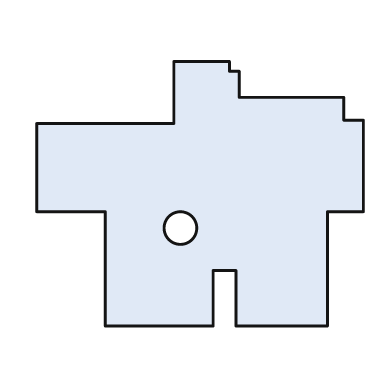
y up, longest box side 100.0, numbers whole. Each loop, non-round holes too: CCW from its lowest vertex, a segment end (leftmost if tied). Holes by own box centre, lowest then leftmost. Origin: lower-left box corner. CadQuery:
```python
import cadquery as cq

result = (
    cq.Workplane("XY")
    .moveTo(21.0, 0.0)
    .lineTo(54.0, 0.0)
    .lineTo(54.0, 17.0)
    .lineTo(61.0, 17.0)
    .lineTo(61.0, 0.0)
    .lineTo(89.0, 0.0)
    .lineTo(89.0, 35.0)
    .lineTo(100.0, 35.0)
    .lineTo(100.0, 63.0)
    .lineTo(94.0, 63.0)
    .lineTo(94.0, 70.0)
    .lineTo(62.0, 70.0)
    .lineTo(62.0, 78.0)
    .lineTo(59.0, 78.0)
    .lineTo(59.0, 81.0)
    .lineTo(42.0, 81.0)
    .lineTo(42.0, 62.0)
    .lineTo(0.0, 62.0)
    .lineTo(0.0, 35.0)
    .lineTo(21.0, 35.0)
    .close()
    .moveTo(44.0, 30.0)
    .circle(5.0)
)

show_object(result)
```